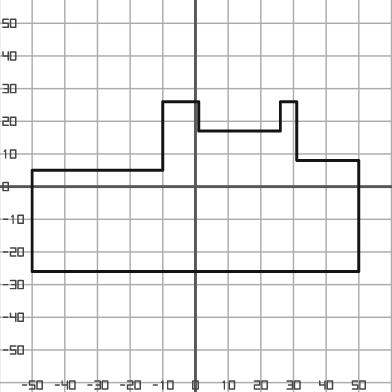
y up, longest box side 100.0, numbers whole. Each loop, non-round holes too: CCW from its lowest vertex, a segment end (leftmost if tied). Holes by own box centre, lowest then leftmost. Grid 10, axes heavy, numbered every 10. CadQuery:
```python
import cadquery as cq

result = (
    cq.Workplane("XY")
    .moveTo(-50.0, -26.0)
    .lineTo(50.0, -26.0)
    .lineTo(50.0, 8.0)
    .lineTo(31.0, 8.0)
    .lineTo(31.0, 26.0)
    .lineTo(26.0, 26.0)
    .lineTo(26.0, 17.0)
    .lineTo(1.0, 17.0)
    .lineTo(1.0, 26.0)
    .lineTo(-10.0, 26.0)
    .lineTo(-10.0, 5.0)
    .lineTo(-50.0, 5.0)
    .close()
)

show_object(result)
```